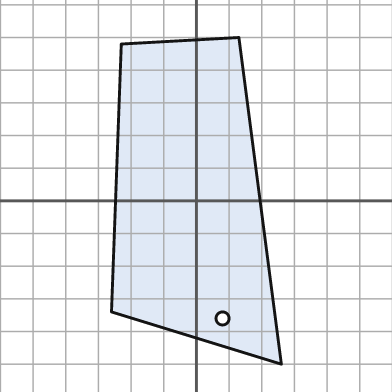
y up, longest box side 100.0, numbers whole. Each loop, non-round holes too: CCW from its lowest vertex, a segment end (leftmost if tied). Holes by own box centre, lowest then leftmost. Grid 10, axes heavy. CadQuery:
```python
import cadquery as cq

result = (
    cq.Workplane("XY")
    .moveTo(26.0, -50.0)
    .lineTo(13.0, 50.0)
    .lineTo(-23.0, 48.0)
    .lineTo(-26.0, -34.0)
    .close()
    .moveTo(8.0, -36.0)
    .circle(2.0)
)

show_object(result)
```